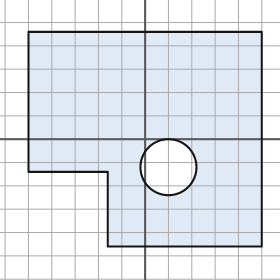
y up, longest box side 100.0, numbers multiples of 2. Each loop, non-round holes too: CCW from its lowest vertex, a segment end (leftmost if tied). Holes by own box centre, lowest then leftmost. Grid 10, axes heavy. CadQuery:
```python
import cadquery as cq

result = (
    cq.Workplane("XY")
    .moveTo(-16.0, -46.0)
    .lineTo(50.0, -46.0)
    .lineTo(50.0, 46.0)
    .lineTo(-50.0, 46.0)
    .lineTo(-50.0, -14.0)
    .lineTo(-16.0, -14.0)
    .close()
    .moveTo(10.0, -12.0)
    .circle(12.0)
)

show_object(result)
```